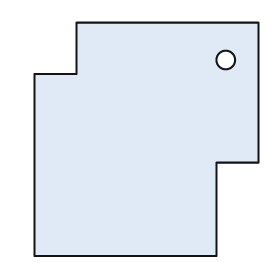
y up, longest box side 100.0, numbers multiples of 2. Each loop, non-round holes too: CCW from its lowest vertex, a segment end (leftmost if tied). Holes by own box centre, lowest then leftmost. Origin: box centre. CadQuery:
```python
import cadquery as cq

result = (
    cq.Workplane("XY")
    .moveTo(-48.0, -50.0)
    .lineTo(30.0, -50.0)
    .lineTo(30.0, -10.0)
    .lineTo(48.0, -10.0)
    .lineTo(48.0, 50.0)
    .lineTo(-30.0, 50.0)
    .lineTo(-30.0, 28.0)
    .lineTo(-48.0, 28.0)
    .close()
    .moveTo(34.0, 34.0)
    .circle(4.0)
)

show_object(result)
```